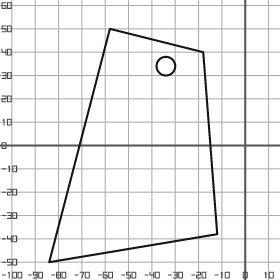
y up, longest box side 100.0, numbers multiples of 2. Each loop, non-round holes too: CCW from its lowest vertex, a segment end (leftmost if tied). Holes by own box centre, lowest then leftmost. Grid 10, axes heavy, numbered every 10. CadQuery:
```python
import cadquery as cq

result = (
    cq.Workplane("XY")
    .moveTo(-84.0, -50.0)
    .lineTo(-12.0, -38.0)
    .lineTo(-18.0, 40.0)
    .lineTo(-58.0, 50.0)
    .close()
    .moveTo(-34.0, 34.0)
    .circle(4.0)
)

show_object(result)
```